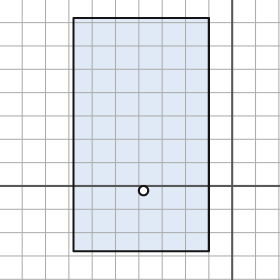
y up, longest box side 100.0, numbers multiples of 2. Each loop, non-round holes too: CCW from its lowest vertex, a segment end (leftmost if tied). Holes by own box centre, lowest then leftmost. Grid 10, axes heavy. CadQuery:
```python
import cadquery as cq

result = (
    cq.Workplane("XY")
    .moveTo(-68.0, -28.0)
    .lineTo(-10.0, -28.0)
    .lineTo(-10.0, 72.0)
    .lineTo(-68.0, 72.0)
    .close()
    .moveTo(-38.0, -2.0)
    .circle(2.0)
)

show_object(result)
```